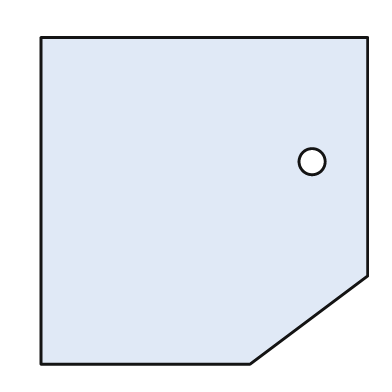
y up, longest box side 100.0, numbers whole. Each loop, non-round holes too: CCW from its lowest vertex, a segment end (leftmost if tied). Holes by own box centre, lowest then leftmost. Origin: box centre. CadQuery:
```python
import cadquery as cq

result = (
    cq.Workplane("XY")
    .moveTo(-50.0, -50.0)
    .lineTo(14.0, -50.0)
    .lineTo(50.0, -23.0)
    .lineTo(50.0, 50.0)
    .lineTo(-50.0, 50.0)
    .close()
    .moveTo(33.0, 12.0)
    .circle(4.0)
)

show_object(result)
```